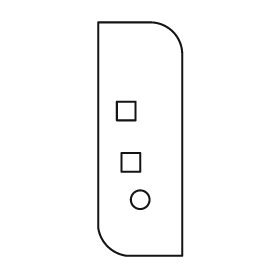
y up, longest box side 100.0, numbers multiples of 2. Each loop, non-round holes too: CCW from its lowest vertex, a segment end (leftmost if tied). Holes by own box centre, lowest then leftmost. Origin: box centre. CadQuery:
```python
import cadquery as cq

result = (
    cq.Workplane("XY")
    .moveTo(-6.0, -50.0)
    .lineTo(18.0, -50.0)
    .lineTo(18.0, 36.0)
    .threePointArc((14.0, 46.0), (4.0, 50.0))
    .lineTo(-18.0, 50.0)
    .lineTo(-18.0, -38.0)
    .threePointArc((-14.0, -46.0), (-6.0, -50.0))
    .close()
    .moveTo(0.0, -26.0)
    .circle(4.0)
    .moveTo(-8.0, -14.0)
    .lineTo(0.0, -14.0)
    .lineTo(0.0, -6.0)
    .lineTo(-8.0, -6.0)
    .close()
    .moveTo(-10.0, 8.0)
    .lineTo(-2.0, 8.0)
    .lineTo(-2.0, 16.0)
    .lineTo(-10.0, 16.0)
    .close()
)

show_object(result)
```